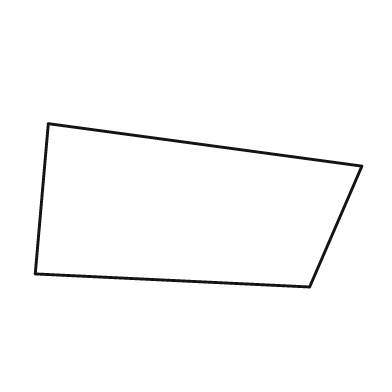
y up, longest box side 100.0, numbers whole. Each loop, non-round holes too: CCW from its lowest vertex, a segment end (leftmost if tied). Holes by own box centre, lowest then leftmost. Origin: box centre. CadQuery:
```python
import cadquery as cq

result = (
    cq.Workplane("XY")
    .moveTo(34.0, -25.0)
    .lineTo(50.0, 12.0)
    .lineTo(-46.0, 25.0)
    .lineTo(-50.0, -21.0)
    .close()
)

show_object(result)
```